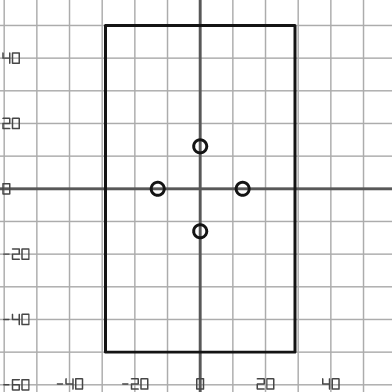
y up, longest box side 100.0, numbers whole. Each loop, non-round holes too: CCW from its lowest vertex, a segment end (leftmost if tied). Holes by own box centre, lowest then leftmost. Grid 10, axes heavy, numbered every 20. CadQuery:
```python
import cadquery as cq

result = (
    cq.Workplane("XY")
    .moveTo(-29.0, -50.0)
    .lineTo(29.0, -50.0)
    .lineTo(29.0, 50.0)
    .lineTo(-29.0, 50.0)
    .close()
    .moveTo(0.0, -13.0)
    .circle(2.0)
    .moveTo(-13.0, 0.0)
    .circle(2.0)
    .moveTo(13.0, 0.0)
    .circle(2.0)
    .moveTo(0.0, 13.0)
    .circle(2.0)
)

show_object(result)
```